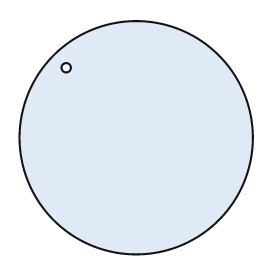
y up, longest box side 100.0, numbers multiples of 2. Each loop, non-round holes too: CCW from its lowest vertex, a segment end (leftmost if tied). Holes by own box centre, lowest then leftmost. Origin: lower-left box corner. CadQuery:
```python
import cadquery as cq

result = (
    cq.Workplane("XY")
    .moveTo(50.0, 50.0)
    .circle(50.0)
    .moveTo(20.0, 80.0)
    .circle(2.0)
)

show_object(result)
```